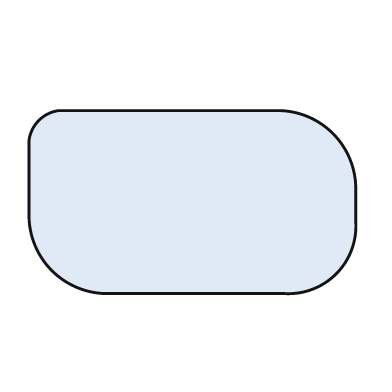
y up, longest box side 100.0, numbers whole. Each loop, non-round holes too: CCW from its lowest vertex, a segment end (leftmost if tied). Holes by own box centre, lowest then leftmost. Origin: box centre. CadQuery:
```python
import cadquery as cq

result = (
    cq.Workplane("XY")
    .moveTo(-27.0, -28.0)
    .lineTo(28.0, -28.0)
    .threePointArc((44.0, -22.0), (50.0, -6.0))
    .lineTo(50.0, 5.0)
    .threePointArc((43.0, 21.0), (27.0, 28.0))
    .lineTo(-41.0, 28.0)
    .threePointArc((-47.0, 25.0), (-50.0, 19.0))
    .lineTo(-50.0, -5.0)
    .threePointArc((-43.0, -21.0), (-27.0, -28.0))
    .close()
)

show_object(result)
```